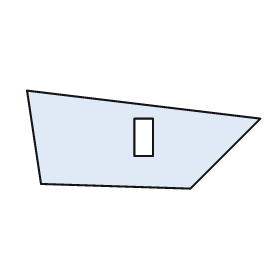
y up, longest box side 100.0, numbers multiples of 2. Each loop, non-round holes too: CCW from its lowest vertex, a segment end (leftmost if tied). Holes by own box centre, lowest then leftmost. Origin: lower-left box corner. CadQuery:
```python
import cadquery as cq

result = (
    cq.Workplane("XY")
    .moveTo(70.0, 0.0)
    .lineTo(100.0, 30.0)
    .lineTo(0.0, 42.0)
    .lineTo(6.0, 2.0)
    .close()
    .moveTo(46.0, 14.0)
    .lineTo(54.0, 14.0)
    .lineTo(54.0, 30.0)
    .lineTo(46.0, 30.0)
    .close()
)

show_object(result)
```